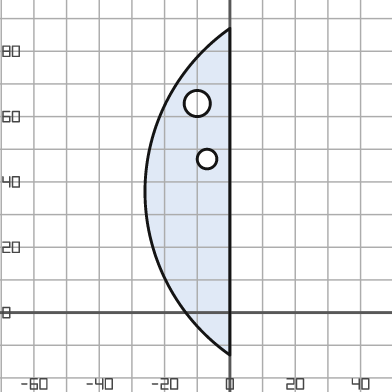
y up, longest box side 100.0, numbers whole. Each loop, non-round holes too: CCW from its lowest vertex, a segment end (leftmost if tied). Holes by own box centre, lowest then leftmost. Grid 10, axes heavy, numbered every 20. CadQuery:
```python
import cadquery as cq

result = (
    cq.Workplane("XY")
    .moveTo(0.0, -13.0)
    .lineTo(0.0, 87.0)
    .threePointArc((-26.0, 37.0), (0.0, -13.0))
    .close()
    .moveTo(-7.0, 47.0)
    .circle(3.0)
    .moveTo(-10.0, 64.0)
    .circle(4.0)
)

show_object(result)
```